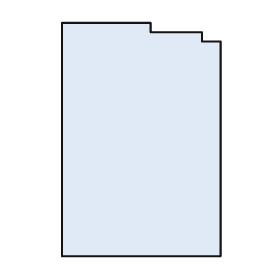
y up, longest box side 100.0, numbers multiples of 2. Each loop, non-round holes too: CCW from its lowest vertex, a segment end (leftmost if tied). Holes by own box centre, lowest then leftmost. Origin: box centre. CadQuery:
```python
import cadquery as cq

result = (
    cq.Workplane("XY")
    .moveTo(-34.0, -50.0)
    .lineTo(34.0, -50.0)
    .lineTo(34.0, 42.0)
    .lineTo(26.0, 42.0)
    .lineTo(26.0, 46.0)
    .lineTo(4.0, 46.0)
    .lineTo(4.0, 50.0)
    .lineTo(-34.0, 50.0)
    .close()
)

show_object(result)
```